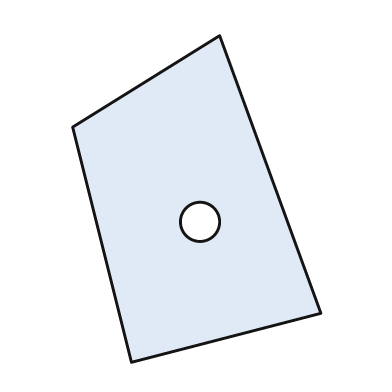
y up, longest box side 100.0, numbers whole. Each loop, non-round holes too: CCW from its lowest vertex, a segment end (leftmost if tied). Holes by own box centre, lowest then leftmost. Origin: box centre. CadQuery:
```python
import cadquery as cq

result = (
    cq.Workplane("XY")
    .moveTo(-20.0, -50.0)
    .lineTo(38.0, -35.0)
    .lineTo(7.0, 50.0)
    .lineTo(-38.0, 22.0)
    .close()
    .moveTo(1.0, -7.0)
    .circle(6.0)
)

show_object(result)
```